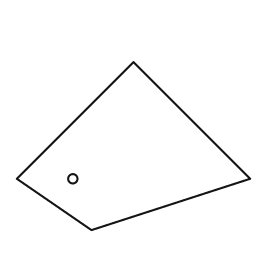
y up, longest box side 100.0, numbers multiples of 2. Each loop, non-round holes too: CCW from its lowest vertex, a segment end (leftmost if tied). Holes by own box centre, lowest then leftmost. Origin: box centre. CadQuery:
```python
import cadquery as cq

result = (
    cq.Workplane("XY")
    .moveTo(-18.0, -36.0)
    .lineTo(50.0, -14.0)
    .lineTo(0.0, 36.0)
    .lineTo(-50.0, -14.0)
    .close()
    .moveTo(-26.0, -14.0)
    .circle(2.0)
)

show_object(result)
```